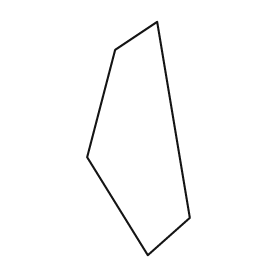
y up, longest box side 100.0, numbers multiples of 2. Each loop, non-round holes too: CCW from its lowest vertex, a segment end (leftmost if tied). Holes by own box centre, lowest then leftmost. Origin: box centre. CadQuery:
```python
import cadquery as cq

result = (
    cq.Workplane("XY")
    .moveTo(4.0, -50.0)
    .lineTo(22.0, -34.0)
    .lineTo(8.0, 50.0)
    .lineTo(-10.0, 38.0)
    .lineTo(-22.0, -8.0)
    .close()
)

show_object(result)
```